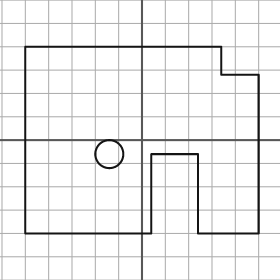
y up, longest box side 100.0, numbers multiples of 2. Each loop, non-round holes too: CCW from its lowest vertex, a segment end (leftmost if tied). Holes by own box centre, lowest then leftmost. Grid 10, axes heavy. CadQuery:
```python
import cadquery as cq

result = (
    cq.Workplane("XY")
    .moveTo(-50.0, -40.0)
    .lineTo(4.0, -40.0)
    .lineTo(4.0, -6.0)
    .lineTo(24.0, -6.0)
    .lineTo(24.0, -40.0)
    .lineTo(50.0, -40.0)
    .lineTo(50.0, 28.0)
    .lineTo(34.0, 28.0)
    .lineTo(34.0, 40.0)
    .lineTo(-50.0, 40.0)
    .close()
    .moveTo(-14.0, -6.0)
    .circle(6.0)
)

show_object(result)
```